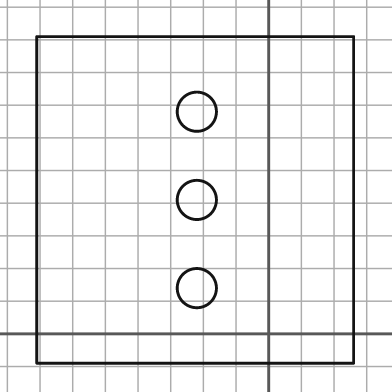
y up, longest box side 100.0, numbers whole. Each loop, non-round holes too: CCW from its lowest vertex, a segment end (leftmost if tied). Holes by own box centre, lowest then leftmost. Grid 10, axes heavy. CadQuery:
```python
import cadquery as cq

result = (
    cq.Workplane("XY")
    .moveTo(-71.0, -9.0)
    .lineTo(26.0, -9.0)
    .lineTo(26.0, 91.0)
    .lineTo(-71.0, 91.0)
    .close()
    .moveTo(-22.0, 14.0)
    .circle(6.0)
    .moveTo(-22.0, 41.0)
    .circle(6.0)
    .moveTo(-22.0, 68.0)
    .circle(6.0)
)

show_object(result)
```